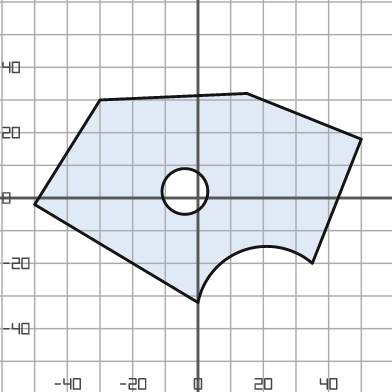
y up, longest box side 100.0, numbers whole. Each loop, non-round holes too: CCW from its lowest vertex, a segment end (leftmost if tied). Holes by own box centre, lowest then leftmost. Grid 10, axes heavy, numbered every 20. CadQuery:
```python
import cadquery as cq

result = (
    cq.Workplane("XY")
    .moveTo(0.0, -32.0)
    .threePointArc((14.0, -16.0), (35.0, -20.0))
    .lineTo(50.0, 18.0)
    .lineTo(15.0, 32.0)
    .lineTo(-30.0, 30.0)
    .lineTo(-50.0, -2.0)
    .close()
    .moveTo(-4.0, 2.0)
    .circle(7.0)
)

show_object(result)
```